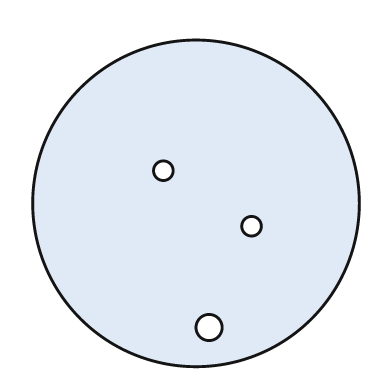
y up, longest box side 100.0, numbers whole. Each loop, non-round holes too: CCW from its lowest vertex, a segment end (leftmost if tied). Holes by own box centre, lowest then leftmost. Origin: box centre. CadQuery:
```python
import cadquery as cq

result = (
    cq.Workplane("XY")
    .moveTo(0.0, 0.0)
    .circle(50.0)
    .moveTo(4.0, -38.0)
    .circle(4.0)
    .moveTo(17.0, -7.0)
    .circle(3.0)
    .moveTo(-10.0, 10.0)
    .circle(3.0)
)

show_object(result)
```